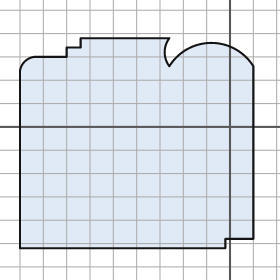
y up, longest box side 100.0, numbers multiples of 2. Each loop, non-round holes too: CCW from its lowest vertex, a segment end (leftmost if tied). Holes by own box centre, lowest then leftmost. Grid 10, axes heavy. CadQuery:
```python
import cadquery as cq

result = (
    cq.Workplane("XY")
    .moveTo(-90.0, -52.0)
    .lineTo(-2.0, -52.0)
    .lineTo(-2.0, -48.0)
    .lineTo(10.0, -48.0)
    .lineTo(10.0, 26.0)
    .threePointArc((-8.0, 36.0), (-26.0, 26.0))
    .threePointArc((-28.0, 32.0), (-26.0, 38.0))
    .lineTo(-64.0, 38.0)
    .lineTo(-64.0, 34.0)
    .lineTo(-70.0, 34.0)
    .lineTo(-70.0, 30.0)
    .lineTo(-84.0, 30.0)
    .threePointArc((-88.0, 28.0), (-90.0, 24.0))
    .close()
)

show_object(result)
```